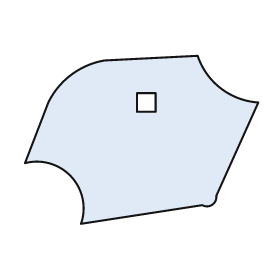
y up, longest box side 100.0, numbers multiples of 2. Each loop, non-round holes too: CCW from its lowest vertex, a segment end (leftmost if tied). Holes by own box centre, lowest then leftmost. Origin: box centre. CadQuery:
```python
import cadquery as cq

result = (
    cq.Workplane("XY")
    .moveTo(-26.0, -36.0)
    .lineTo(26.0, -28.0)
    .threePointArc((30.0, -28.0), (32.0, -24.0))
    .lineTo(50.0, 16.0)
    .threePointArc((34.0, 22.0), (24.0, 36.0))
    .lineTo(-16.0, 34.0)
    .threePointArc((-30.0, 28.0), (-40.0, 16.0))
    .lineTo(-50.0, -10.0)
    .threePointArc((-30.0, -16.0), (-26.0, -36.0))
    .close()
    .moveTo(-2.0, 12.0)
    .lineTo(6.0, 12.0)
    .lineTo(6.0, 20.0)
    .lineTo(-2.0, 20.0)
    .close()
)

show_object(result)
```